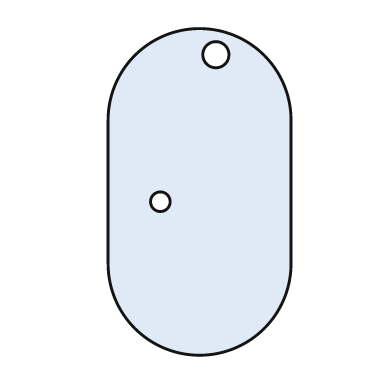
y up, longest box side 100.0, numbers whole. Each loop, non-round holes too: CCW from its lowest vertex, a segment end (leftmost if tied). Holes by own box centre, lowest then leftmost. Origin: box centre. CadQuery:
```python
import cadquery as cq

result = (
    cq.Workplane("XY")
    .moveTo(-28.0, -22.0)
    .threePointArc((0.0, -50.0), (28.0, -22.0))
    .lineTo(28.0, 22.0)
    .threePointArc((0.0, 50.0), (-28.0, 22.0))
    .close()
    .moveTo(-12.0, -3.0)
    .circle(3.0)
    .moveTo(5.0, 42.0)
    .circle(4.0)
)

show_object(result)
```